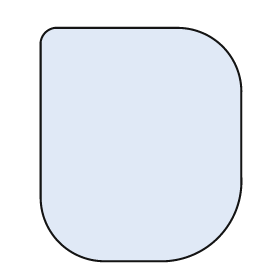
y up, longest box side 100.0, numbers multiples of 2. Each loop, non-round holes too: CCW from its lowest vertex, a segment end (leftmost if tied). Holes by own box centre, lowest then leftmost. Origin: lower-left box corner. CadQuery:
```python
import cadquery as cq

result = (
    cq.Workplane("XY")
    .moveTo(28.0, 0.0)
    .lineTo(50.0, 0.0)
    .threePointArc((76.0, 10.0), (86.0, 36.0))
    .lineTo(86.0, 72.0)
    .threePointArc((78.0, 92.0), (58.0, 100.0))
    .lineTo(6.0, 100.0)
    .threePointArc((2.0, 98.0), (0.0, 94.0))
    .lineTo(0.0, 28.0)
    .threePointArc((8.0, 8.0), (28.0, 0.0))
    .close()
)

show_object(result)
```